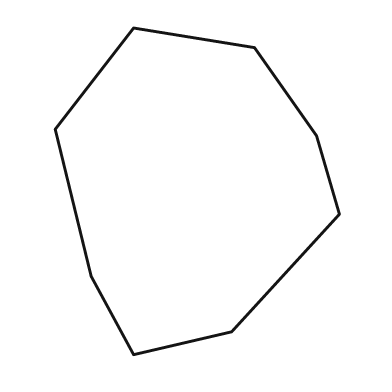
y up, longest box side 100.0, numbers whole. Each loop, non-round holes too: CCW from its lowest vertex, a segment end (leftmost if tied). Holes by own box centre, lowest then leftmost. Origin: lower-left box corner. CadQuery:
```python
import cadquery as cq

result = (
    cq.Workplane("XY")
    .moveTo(24.0, 0.0)
    .lineTo(54.0, 7.0)
    .lineTo(87.0, 43.0)
    .lineTo(80.0, 67.0)
    .lineTo(61.0, 94.0)
    .lineTo(24.0, 100.0)
    .lineTo(0.0, 69.0)
    .lineTo(11.0, 24.0)
    .close()
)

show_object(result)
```